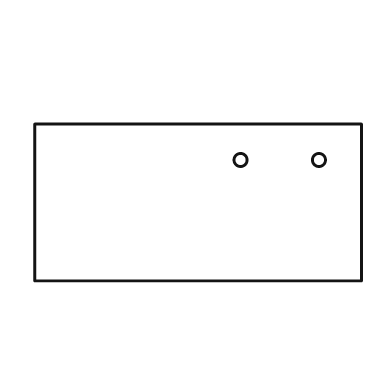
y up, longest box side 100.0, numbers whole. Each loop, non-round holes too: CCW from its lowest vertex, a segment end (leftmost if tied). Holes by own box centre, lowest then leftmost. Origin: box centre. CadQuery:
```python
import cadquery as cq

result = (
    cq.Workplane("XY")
    .moveTo(-50.0, -24.0)
    .lineTo(50.0, -24.0)
    .lineTo(50.0, 24.0)
    .lineTo(-50.0, 24.0)
    .close()
    .moveTo(13.0, 13.0)
    .circle(2.0)
    .moveTo(37.0, 13.0)
    .circle(2.0)
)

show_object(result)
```